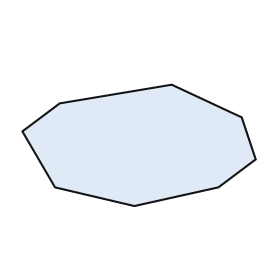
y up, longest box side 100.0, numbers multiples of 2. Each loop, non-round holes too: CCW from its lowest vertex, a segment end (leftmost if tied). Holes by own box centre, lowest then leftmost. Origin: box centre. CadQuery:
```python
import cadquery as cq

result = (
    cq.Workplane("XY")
    .moveTo(-2.0, -26.0)
    .lineTo(34.0, -18.0)
    .lineTo(50.0, -6.0)
    .lineTo(44.0, 12.0)
    .lineTo(14.0, 26.0)
    .lineTo(-34.0, 18.0)
    .lineTo(-50.0, 6.0)
    .lineTo(-36.0, -18.0)
    .close()
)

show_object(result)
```